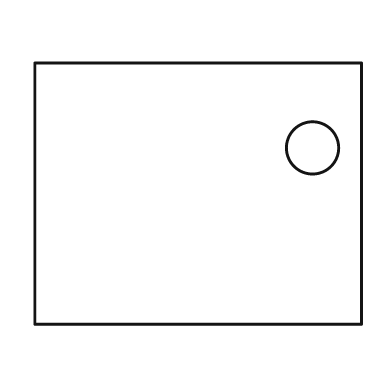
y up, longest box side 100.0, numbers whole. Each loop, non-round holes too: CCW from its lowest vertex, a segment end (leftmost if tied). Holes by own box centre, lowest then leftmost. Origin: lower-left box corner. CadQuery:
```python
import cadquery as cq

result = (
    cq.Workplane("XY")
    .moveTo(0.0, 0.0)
    .lineTo(100.0, 0.0)
    .lineTo(100.0, 80.0)
    .lineTo(0.0, 80.0)
    .close()
    .moveTo(85.0, 54.0)
    .circle(8.0)
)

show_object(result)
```